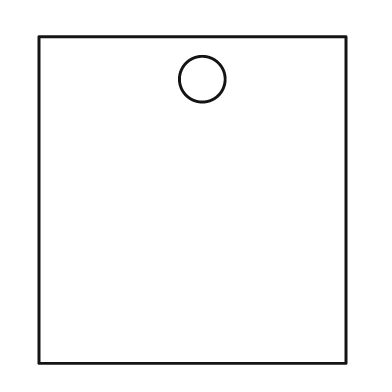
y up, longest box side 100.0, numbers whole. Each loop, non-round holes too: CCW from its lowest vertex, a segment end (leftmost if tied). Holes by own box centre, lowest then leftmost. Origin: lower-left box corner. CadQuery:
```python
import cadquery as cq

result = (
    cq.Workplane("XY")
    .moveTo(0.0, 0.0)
    .lineTo(94.0, 0.0)
    .lineTo(94.0, 100.0)
    .lineTo(0.0, 100.0)
    .close()
    .moveTo(50.0, 87.0)
    .circle(7.0)
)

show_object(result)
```